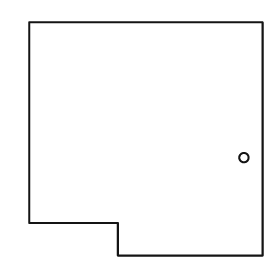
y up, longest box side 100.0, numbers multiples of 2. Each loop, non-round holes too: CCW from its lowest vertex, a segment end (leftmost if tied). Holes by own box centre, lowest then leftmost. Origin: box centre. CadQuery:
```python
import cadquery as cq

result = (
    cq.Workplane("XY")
    .moveTo(-12.0, -50.0)
    .lineTo(50.0, -50.0)
    .lineTo(50.0, 50.0)
    .lineTo(-50.0, 50.0)
    .lineTo(-50.0, -36.0)
    .lineTo(-12.0, -36.0)
    .close()
    .moveTo(42.0, -8.0)
    .circle(2.0)
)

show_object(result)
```